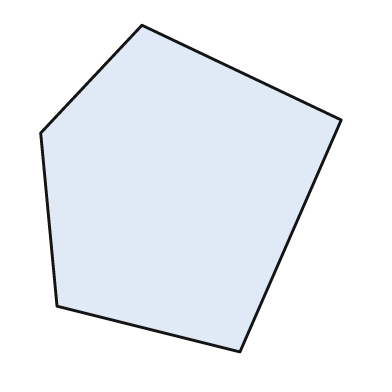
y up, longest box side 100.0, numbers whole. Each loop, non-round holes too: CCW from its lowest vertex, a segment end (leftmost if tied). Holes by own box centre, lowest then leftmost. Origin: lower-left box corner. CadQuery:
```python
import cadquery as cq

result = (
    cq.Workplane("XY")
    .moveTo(61.0, 0.0)
    .lineTo(92.0, 71.0)
    .lineTo(31.0, 100.0)
    .lineTo(0.0, 67.0)
    .lineTo(5.0, 14.0)
    .close()
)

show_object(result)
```